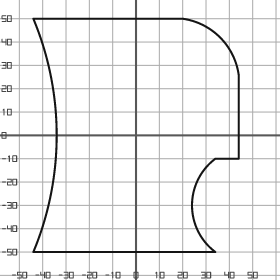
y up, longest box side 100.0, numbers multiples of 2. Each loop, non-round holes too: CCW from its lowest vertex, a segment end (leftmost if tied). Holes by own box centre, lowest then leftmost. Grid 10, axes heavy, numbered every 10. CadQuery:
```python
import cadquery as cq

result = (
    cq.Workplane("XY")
    .moveTo(-44.0, -50.0)
    .lineTo(34.0, -50.0)
    .threePointArc((24.0, -30.0), (34.0, -10.0))
    .lineTo(44.0, -10.0)
    .lineTo(44.0, 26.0)
    .threePointArc((36.0, 42.0), (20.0, 50.0))
    .lineTo(-44.0, 50.0)
    .threePointArc((-34.0, 0.0), (-44.0, -50.0))
    .close()
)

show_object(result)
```